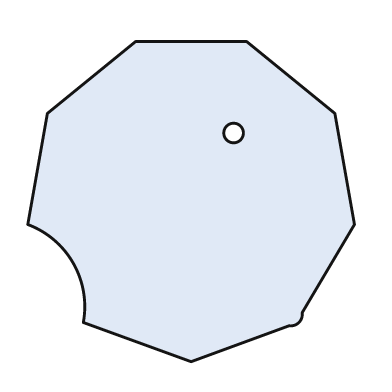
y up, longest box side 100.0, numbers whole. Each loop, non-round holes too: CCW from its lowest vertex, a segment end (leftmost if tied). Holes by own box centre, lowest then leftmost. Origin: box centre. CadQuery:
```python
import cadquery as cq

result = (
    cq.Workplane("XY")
    .moveTo(0.0, -49.0)
    .lineTo(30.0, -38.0)
    .threePointArc((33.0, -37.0), (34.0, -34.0))
    .lineTo(50.0, -7.0)
    .lineTo(44.0, 27.0)
    .lineTo(17.0, 49.0)
    .lineTo(-17.0, 49.0)
    .lineTo(-44.0, 27.0)
    .lineTo(-50.0, -7.0)
    .threePointArc((-36.0, -19.0), (-33.0, -37.0))
    .close()
    .moveTo(13.0, 21.0)
    .circle(3.0)
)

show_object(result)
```